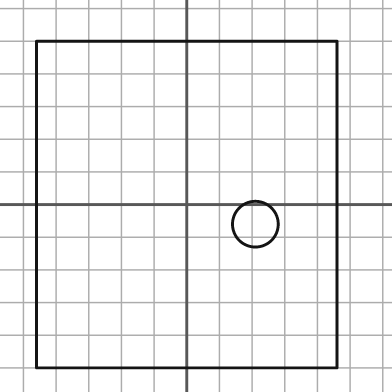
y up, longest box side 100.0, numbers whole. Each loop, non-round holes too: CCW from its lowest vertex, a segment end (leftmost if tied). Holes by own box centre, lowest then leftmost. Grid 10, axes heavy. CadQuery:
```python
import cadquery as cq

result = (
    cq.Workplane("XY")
    .moveTo(-46.0, -50.0)
    .lineTo(46.0, -50.0)
    .lineTo(46.0, 50.0)
    .lineTo(-46.0, 50.0)
    .close()
    .moveTo(21.0, -6.0)
    .circle(7.0)
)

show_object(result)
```